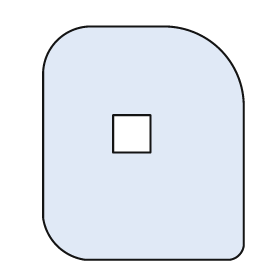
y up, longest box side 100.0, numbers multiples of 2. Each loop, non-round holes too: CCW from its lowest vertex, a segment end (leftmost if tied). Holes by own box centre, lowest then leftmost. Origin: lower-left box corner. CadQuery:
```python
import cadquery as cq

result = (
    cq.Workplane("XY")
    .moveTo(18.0, 0.0)
    .lineTo(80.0, 0.0)
    .threePointArc((84.0, 2.0), (86.0, 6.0))
    .lineTo(86.0, 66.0)
    .threePointArc((76.0, 90.0), (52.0, 100.0))
    .lineTo(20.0, 100.0)
    .threePointArc((6.0, 94.0), (0.0, 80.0))
    .lineTo(0.0, 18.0)
    .threePointArc((6.0, 6.0), (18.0, 0.0))
    .close()
    .moveTo(30.0, 46.0)
    .lineTo(46.0, 46.0)
    .lineTo(46.0, 62.0)
    .lineTo(30.0, 62.0)
    .close()
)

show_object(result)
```